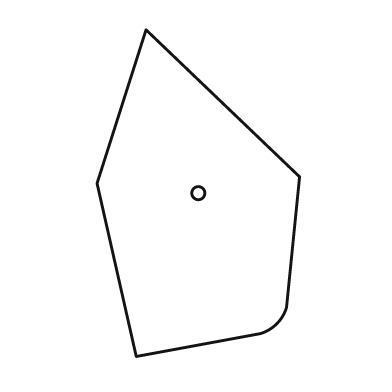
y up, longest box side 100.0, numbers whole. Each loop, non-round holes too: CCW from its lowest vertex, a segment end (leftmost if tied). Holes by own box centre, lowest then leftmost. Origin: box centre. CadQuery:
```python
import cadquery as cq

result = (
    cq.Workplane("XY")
    .moveTo(-19.0, -50.0)
    .lineTo(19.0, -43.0)
    .threePointArc((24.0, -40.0), (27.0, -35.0))
    .lineTo(31.0, 5.0)
    .lineTo(-16.0, 50.0)
    .lineTo(-31.0, 3.0)
    .close()
    .moveTo(0.0, 0.0)
    .circle(2.0)
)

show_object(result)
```